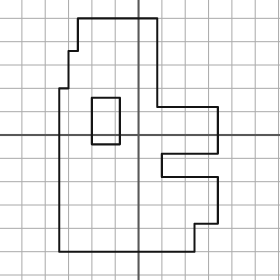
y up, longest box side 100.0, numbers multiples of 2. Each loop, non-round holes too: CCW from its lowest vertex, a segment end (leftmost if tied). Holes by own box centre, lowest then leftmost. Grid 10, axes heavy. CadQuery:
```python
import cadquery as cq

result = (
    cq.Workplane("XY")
    .moveTo(-34.0, -50.0)
    .lineTo(24.0, -50.0)
    .lineTo(24.0, -38.0)
    .lineTo(34.0, -38.0)
    .lineTo(34.0, -18.0)
    .lineTo(10.0, -18.0)
    .lineTo(10.0, -8.0)
    .lineTo(34.0, -8.0)
    .lineTo(34.0, 12.0)
    .lineTo(8.0, 12.0)
    .lineTo(8.0, 50.0)
    .lineTo(-26.0, 50.0)
    .lineTo(-26.0, 36.0)
    .lineTo(-30.0, 36.0)
    .lineTo(-30.0, 20.0)
    .lineTo(-34.0, 20.0)
    .close()
    .moveTo(-20.0, -4.0)
    .lineTo(-8.0, -4.0)
    .lineTo(-8.0, 16.0)
    .lineTo(-20.0, 16.0)
    .close()
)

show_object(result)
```